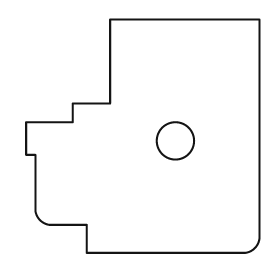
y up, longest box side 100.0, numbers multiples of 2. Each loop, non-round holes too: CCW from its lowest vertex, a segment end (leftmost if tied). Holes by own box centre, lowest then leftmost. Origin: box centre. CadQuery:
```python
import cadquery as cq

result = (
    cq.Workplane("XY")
    .moveTo(-24.0, -50.0)
    .lineTo(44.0, -50.0)
    .threePointArc((48.0, -48.0), (50.0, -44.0))
    .lineTo(50.0, 50.0)
    .lineTo(-14.0, 50.0)
    .lineTo(-14.0, 14.0)
    .lineTo(-30.0, 14.0)
    .lineTo(-30.0, 6.0)
    .lineTo(-50.0, 6.0)
    .lineTo(-50.0, -8.0)
    .lineTo(-46.0, -8.0)
    .lineTo(-46.0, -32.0)
    .threePointArc((-44.0, -36.0), (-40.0, -38.0))
    .lineTo(-24.0, -38.0)
    .close()
    .moveTo(14.0, -2.0)
    .circle(8.0)
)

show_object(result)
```